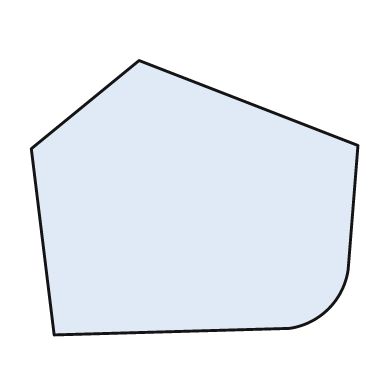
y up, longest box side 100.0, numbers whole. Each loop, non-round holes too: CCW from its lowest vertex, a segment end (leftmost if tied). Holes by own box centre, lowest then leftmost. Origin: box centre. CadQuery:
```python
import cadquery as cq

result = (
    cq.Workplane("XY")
    .moveTo(-43.0, -42.0)
    .lineTo(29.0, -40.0)
    .threePointArc((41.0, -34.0), (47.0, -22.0))
    .lineTo(50.0, 16.0)
    .lineTo(-17.0, 42.0)
    .lineTo(-50.0, 15.0)
    .close()
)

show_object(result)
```